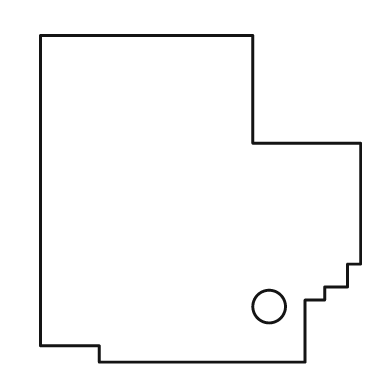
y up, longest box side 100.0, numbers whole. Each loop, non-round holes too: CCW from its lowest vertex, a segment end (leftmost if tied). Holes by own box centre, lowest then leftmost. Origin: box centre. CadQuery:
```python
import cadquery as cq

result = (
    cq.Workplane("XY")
    .moveTo(-31.0, -50.0)
    .lineTo(32.0, -50.0)
    .lineTo(32.0, -31.0)
    .lineTo(38.0, -31.0)
    .lineTo(38.0, -27.0)
    .lineTo(45.0, -27.0)
    .lineTo(45.0, -20.0)
    .lineTo(49.0, -20.0)
    .lineTo(49.0, 17.0)
    .lineTo(16.0, 17.0)
    .lineTo(16.0, 50.0)
    .lineTo(-49.0, 50.0)
    .lineTo(-49.0, -45.0)
    .lineTo(-31.0, -45.0)
    .close()
    .moveTo(21.0, -33.0)
    .circle(5.0)
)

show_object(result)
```